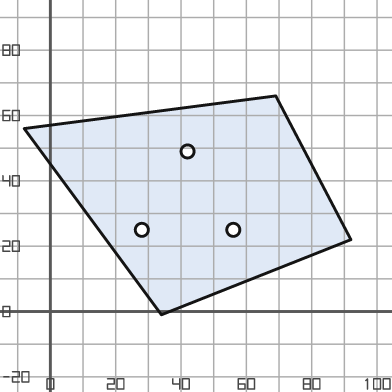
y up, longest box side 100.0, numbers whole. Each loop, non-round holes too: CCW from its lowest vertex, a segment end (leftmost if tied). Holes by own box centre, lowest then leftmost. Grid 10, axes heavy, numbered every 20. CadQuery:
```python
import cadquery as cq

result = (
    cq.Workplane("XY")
    .moveTo(34.0, -1.0)
    .lineTo(92.0, 22.0)
    .lineTo(69.0, 66.0)
    .lineTo(-8.0, 56.0)
    .close()
    .moveTo(28.0, 25.0)
    .circle(2.0)
    .moveTo(56.0, 25.0)
    .circle(2.0)
    .moveTo(42.0, 49.0)
    .circle(2.0)
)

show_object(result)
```